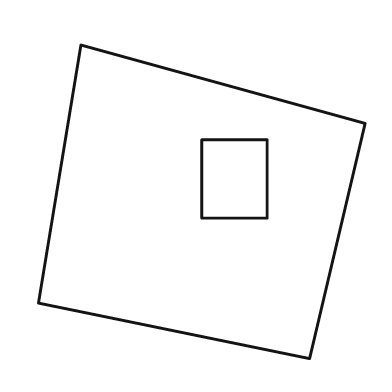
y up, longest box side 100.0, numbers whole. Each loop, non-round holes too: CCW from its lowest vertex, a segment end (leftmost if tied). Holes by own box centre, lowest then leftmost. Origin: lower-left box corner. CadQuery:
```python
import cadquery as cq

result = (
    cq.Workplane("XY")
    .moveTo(83.0, 0.0)
    .lineTo(100.0, 72.0)
    .lineTo(13.0, 96.0)
    .lineTo(0.0, 17.0)
    .close()
    .moveTo(50.0, 43.0)
    .lineTo(70.0, 43.0)
    .lineTo(70.0, 67.0)
    .lineTo(50.0, 67.0)
    .close()
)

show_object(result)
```